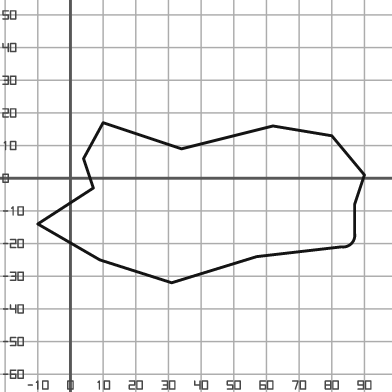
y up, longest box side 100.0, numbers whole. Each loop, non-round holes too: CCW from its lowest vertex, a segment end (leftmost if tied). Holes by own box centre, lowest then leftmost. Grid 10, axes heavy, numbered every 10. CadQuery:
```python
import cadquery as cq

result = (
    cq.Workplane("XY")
    .moveTo(31.0, -32.0)
    .lineTo(57.0, -24.0)
    .lineTo(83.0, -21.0)
    .threePointArc((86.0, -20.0), (87.0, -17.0))
    .lineTo(87.0, -8.0)
    .lineTo(90.0, 1.0)
    .lineTo(80.0, 13.0)
    .lineTo(62.0, 16.0)
    .lineTo(34.0, 9.0)
    .lineTo(10.0, 17.0)
    .lineTo(4.0, 6.0)
    .lineTo(7.0, -3.0)
    .lineTo(-10.0, -14.0)
    .lineTo(9.0, -25.0)
    .close()
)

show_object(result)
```